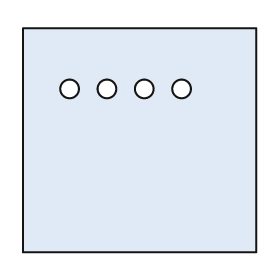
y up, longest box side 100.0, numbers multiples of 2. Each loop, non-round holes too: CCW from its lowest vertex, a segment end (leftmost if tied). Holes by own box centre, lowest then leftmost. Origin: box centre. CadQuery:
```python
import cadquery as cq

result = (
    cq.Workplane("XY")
    .moveTo(-50.0, -48.0)
    .lineTo(50.0, -48.0)
    .lineTo(50.0, 48.0)
    .lineTo(-50.0, 48.0)
    .close()
    .moveTo(-30.0, 22.0)
    .circle(4.0)
    .moveTo(-14.0, 22.0)
    .circle(4.0)
    .moveTo(2.0, 22.0)
    .circle(4.0)
    .moveTo(18.0, 22.0)
    .circle(4.0)
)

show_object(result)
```